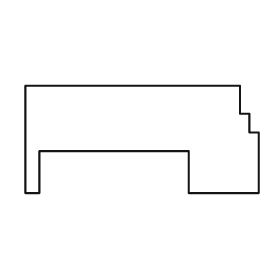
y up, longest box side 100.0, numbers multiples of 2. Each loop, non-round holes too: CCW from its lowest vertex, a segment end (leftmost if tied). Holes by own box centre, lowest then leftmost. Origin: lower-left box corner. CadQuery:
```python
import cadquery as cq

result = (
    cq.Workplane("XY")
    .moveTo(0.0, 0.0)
    .lineTo(6.0, 0.0)
    .lineTo(6.0, 18.0)
    .lineTo(70.0, 18.0)
    .lineTo(70.0, 0.0)
    .lineTo(100.0, 0.0)
    .lineTo(100.0, 26.0)
    .lineTo(96.0, 26.0)
    .lineTo(96.0, 34.0)
    .lineTo(92.0, 34.0)
    .lineTo(92.0, 46.0)
    .lineTo(0.0, 46.0)
    .close()
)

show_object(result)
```